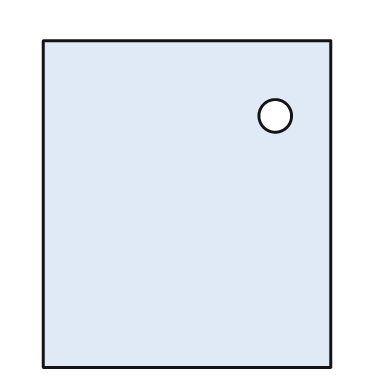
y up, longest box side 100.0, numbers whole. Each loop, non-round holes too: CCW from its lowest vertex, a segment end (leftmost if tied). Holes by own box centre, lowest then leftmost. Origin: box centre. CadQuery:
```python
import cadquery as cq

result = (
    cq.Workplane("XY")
    .moveTo(-44.0, -50.0)
    .lineTo(44.0, -50.0)
    .lineTo(44.0, 50.0)
    .lineTo(-44.0, 50.0)
    .close()
    .moveTo(27.0, 27.0)
    .circle(5.0)
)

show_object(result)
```